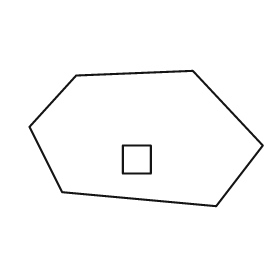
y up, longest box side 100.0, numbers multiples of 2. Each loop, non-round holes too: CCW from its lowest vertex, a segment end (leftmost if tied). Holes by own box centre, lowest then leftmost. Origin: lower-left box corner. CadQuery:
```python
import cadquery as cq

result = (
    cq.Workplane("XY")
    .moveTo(80.0, 0.0)
    .lineTo(100.0, 26.0)
    .lineTo(70.0, 58.0)
    .lineTo(20.0, 56.0)
    .lineTo(0.0, 34.0)
    .lineTo(14.0, 6.0)
    .close()
    .moveTo(40.0, 14.0)
    .lineTo(52.0, 14.0)
    .lineTo(52.0, 26.0)
    .lineTo(40.0, 26.0)
    .close()
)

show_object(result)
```